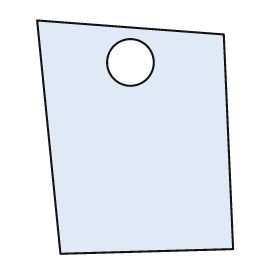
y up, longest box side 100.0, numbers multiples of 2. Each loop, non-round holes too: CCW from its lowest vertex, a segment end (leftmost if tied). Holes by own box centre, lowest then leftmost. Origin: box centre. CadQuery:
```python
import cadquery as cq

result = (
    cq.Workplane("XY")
    .moveTo(-32.0, -50.0)
    .lineTo(42.0, -48.0)
    .lineTo(38.0, 44.0)
    .lineTo(-42.0, 50.0)
    .close()
    .moveTo(-2.0, 32.0)
    .circle(10.0)
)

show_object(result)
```